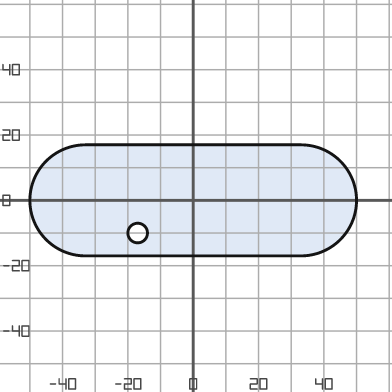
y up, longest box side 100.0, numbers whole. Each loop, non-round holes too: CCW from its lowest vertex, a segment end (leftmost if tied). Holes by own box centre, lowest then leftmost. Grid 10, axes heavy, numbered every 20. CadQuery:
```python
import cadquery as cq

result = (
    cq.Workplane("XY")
    .moveTo(-33.0, -17.0)
    .lineTo(33.0, -17.0)
    .threePointArc((50.0, 0.0), (33.0, 17.0))
    .lineTo(-33.0, 17.0)
    .threePointArc((-50.0, 0.0), (-33.0, -17.0))
    .close()
    .moveTo(-17.0, -10.0)
    .circle(3.0)
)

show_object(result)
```